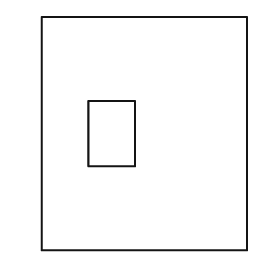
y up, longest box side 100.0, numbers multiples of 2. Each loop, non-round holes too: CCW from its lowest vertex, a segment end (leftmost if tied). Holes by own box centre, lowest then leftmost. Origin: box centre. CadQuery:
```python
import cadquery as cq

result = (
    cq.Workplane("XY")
    .moveTo(-44.0, -50.0)
    .lineTo(44.0, -50.0)
    .lineTo(44.0, 50.0)
    .lineTo(-44.0, 50.0)
    .close()
    .moveTo(-24.0, -14.0)
    .lineTo(-4.0, -14.0)
    .lineTo(-4.0, 14.0)
    .lineTo(-24.0, 14.0)
    .close()
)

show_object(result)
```